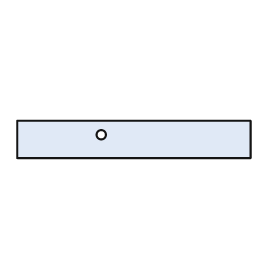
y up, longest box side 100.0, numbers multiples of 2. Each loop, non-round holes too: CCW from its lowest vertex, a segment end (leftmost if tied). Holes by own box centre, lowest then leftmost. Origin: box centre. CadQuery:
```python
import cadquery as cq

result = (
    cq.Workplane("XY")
    .moveTo(-50.0, -8.0)
    .lineTo(50.0, -8.0)
    .lineTo(50.0, 8.0)
    .lineTo(-50.0, 8.0)
    .close()
    .moveTo(-14.0, 2.0)
    .circle(2.0)
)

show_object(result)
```